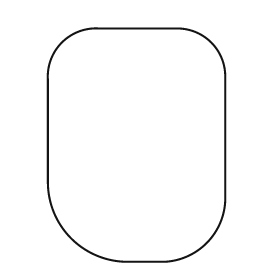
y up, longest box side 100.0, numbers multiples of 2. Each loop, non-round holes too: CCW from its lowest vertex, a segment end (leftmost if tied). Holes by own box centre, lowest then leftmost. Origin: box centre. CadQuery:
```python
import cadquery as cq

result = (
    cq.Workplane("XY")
    .moveTo(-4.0, -50.0)
    .lineTo(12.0, -50.0)
    .threePointArc((30.0, -42.0), (38.0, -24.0))
    .lineTo(38.0, 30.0)
    .threePointArc((32.0, 44.0), (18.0, 50.0))
    .lineTo(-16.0, 50.0)
    .threePointArc((-32.0, 44.0), (-38.0, 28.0))
    .lineTo(-38.0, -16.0)
    .threePointArc((-28.0, -40.0), (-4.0, -50.0))
    .close()
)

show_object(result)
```